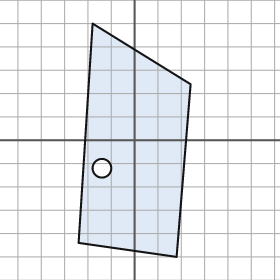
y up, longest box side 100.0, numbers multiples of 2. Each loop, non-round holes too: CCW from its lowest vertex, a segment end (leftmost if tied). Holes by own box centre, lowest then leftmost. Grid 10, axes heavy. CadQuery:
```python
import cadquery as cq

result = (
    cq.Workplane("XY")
    .moveTo(18.0, -50.0)
    .lineTo(24.0, 24.0)
    .lineTo(-18.0, 50.0)
    .lineTo(-24.0, -44.0)
    .close()
    .moveTo(-14.0, -12.0)
    .circle(4.0)
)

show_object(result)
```